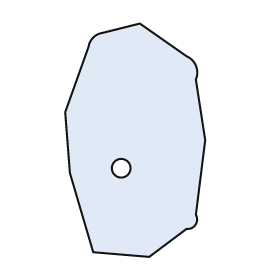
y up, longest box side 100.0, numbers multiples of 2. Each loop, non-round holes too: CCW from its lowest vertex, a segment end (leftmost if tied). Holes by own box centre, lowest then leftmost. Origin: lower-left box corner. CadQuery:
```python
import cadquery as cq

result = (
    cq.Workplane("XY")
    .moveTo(36.0, 0.0)
    .lineTo(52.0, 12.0)
    .threePointArc((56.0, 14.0), (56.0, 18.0))
    .lineTo(60.0, 50.0)
    .lineTo(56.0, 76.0)
    .threePointArc((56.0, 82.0), (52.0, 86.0))
    .lineTo(32.0, 100.0)
    .lineTo(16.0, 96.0)
    .threePointArc((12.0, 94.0), (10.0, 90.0))
    .lineTo(0.0, 62.0)
    .lineTo(2.0, 36.0)
    .lineTo(12.0, 2.0)
    .close()
    .moveTo(24.0, 38.0)
    .circle(4.0)
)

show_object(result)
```